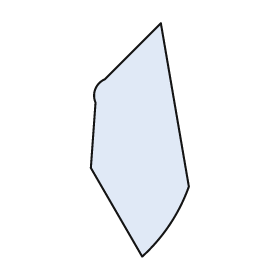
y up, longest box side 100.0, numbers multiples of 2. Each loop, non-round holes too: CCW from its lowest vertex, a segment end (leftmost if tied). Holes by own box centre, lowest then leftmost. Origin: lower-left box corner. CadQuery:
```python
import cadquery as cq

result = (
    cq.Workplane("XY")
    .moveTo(22.0, 0.0)
    .threePointArc((34.0, 14.0), (42.0, 30.0))
    .lineTo(30.0, 100.0)
    .lineTo(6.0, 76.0)
    .threePointArc((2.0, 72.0), (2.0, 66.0))
    .lineTo(0.0, 38.0)
    .close()
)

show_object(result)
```